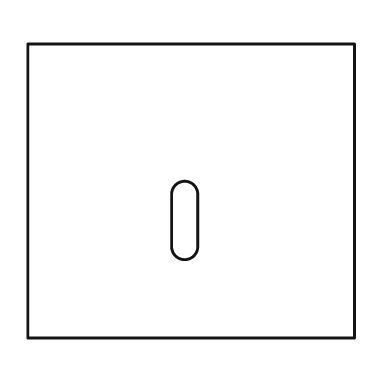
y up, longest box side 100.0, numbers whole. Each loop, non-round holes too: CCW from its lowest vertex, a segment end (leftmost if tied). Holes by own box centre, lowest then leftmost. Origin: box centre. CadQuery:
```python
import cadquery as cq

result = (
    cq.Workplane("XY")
    .moveTo(-50.0, -45.0)
    .lineTo(50.0, -45.0)
    .lineTo(50.0, 45.0)
    .lineTo(-50.0, 45.0)
    .close()
    .moveTo(-6.0, -17.0)
    .threePointArc((-2.0, -21.0), (2.0, -17.0))
    .lineTo(2.0, -1.0)
    .threePointArc((-2.0, 3.0), (-6.0, -1.0))
    .close()
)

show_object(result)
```